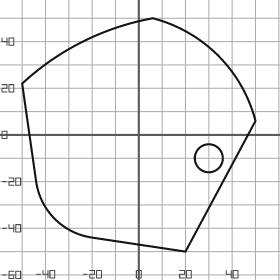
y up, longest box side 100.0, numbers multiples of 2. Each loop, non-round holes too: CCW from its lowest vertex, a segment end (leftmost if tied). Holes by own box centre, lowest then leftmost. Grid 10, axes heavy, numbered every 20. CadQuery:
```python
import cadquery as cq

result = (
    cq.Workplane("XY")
    .moveTo(20.0, -50.0)
    .lineTo(50.0, 6.0)
    .threePointArc((34.0, 34.0), (6.0, 50.0))
    .threePointArc((-24.0, 40.0), (-50.0, 22.0))
    .lineTo(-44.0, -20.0)
    .threePointArc((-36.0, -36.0), (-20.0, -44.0))
    .close()
    .moveTo(30.0, -10.0)
    .circle(6.0)
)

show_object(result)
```